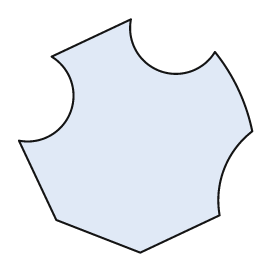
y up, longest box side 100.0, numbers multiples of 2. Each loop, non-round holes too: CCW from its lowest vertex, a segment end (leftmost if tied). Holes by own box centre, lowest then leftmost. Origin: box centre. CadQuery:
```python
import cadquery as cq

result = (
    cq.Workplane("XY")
    .moveTo(2.0, -50.0)
    .lineTo(36.0, -34.0)
    .threePointArc((38.0, -14.0), (50.0, 2.0))
    .threePointArc((44.0, 20.0), (34.0, 36.0))
    .threePointArc((10.0, 28.0), (-2.0, 50.0))
    .lineTo(-36.0, 34.0)
    .threePointArc((-28.0, 10.0), (-50.0, -2.0))
    .lineTo(-34.0, -36.0)
    .close()
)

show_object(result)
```